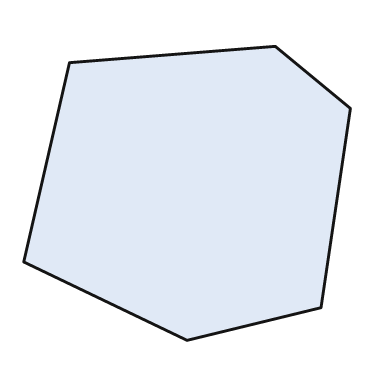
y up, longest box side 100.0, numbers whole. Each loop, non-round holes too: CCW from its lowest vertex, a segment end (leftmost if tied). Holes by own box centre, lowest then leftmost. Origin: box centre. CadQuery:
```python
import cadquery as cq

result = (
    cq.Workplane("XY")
    .moveTo(0.0, -45.0)
    .lineTo(41.0, -35.0)
    .lineTo(50.0, 26.0)
    .lineTo(27.0, 45.0)
    .lineTo(-36.0, 40.0)
    .lineTo(-50.0, -21.0)
    .close()
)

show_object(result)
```